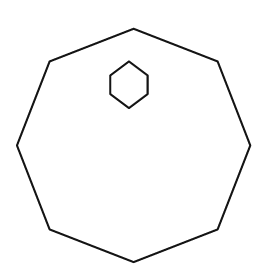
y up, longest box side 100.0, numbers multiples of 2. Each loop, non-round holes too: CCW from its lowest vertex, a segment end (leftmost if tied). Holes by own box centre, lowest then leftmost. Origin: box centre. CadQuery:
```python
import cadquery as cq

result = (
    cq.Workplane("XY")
    .moveTo(0.0, -50.0)
    .lineTo(36.0, -36.0)
    .lineTo(50.0, 0.0)
    .lineTo(36.0, 36.0)
    .lineTo(0.0, 50.0)
    .lineTo(-36.0, 36.0)
    .lineTo(-50.0, 0.0)
    .lineTo(-36.0, -36.0)
    .close()
    .moveTo(-2.0, 16.0)
    .lineTo(6.0, 22.0)
    .lineTo(6.0, 30.0)
    .lineTo(-2.0, 36.0)
    .lineTo(-10.0, 30.0)
    .lineTo(-10.0, 22.0)
    .close()
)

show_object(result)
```